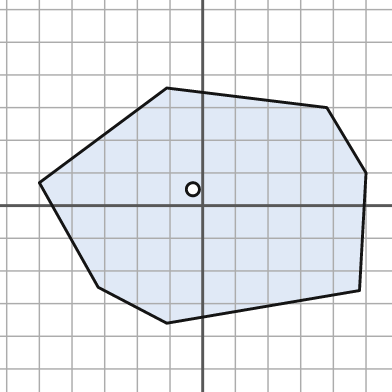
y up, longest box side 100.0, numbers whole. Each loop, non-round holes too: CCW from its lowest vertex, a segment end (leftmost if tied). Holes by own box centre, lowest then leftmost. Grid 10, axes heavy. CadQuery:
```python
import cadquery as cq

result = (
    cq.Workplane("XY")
    .moveTo(-11.0, -36.0)
    .lineTo(48.0, -26.0)
    .lineTo(50.0, 10.0)
    .lineTo(38.0, 30.0)
    .lineTo(-11.0, 36.0)
    .lineTo(-50.0, 7.0)
    .lineTo(-32.0, -25.0)
    .close()
    .moveTo(-3.0, 5.0)
    .circle(2.0)
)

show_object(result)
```